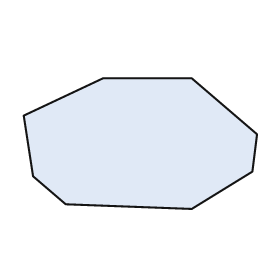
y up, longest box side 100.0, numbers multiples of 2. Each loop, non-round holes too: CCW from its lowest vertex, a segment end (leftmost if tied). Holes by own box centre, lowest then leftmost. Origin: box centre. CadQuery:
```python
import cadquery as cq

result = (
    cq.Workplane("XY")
    .moveTo(22.0, -28.0)
    .lineTo(48.0, -12.0)
    .lineTo(50.0, 4.0)
    .lineTo(22.0, 28.0)
    .lineTo(-16.0, 28.0)
    .lineTo(-50.0, 12.0)
    .lineTo(-46.0, -14.0)
    .lineTo(-32.0, -26.0)
    .close()
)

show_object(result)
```